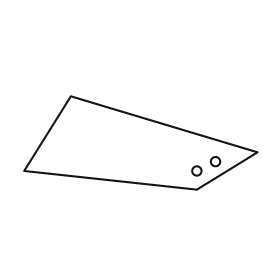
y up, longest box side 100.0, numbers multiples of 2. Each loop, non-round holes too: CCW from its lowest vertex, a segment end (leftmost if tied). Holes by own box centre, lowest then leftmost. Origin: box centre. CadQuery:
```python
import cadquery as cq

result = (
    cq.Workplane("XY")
    .moveTo(24.0, -20.0)
    .lineTo(50.0, -4.0)
    .lineTo(-30.0, 20.0)
    .lineTo(-50.0, -12.0)
    .close()
    .moveTo(24.0, -12.0)
    .circle(2.0)
    .moveTo(32.0, -8.0)
    .circle(2.0)
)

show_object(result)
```